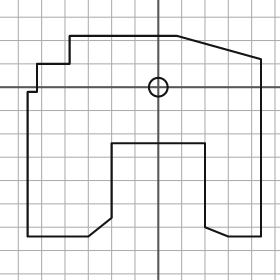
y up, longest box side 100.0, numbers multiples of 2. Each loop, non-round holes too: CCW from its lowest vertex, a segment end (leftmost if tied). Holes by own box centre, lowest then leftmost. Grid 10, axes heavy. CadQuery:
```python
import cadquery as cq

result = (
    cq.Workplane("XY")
    .moveTo(-56.0, -64.0)
    .lineTo(-30.0, -64.0)
    .lineTo(-20.0, -56.0)
    .lineTo(-20.0, -24.0)
    .lineTo(20.0, -24.0)
    .lineTo(20.0, -60.0)
    .lineTo(30.0, -64.0)
    .lineTo(44.0, -64.0)
    .lineTo(44.0, 12.0)
    .lineTo(8.0, 22.0)
    .lineTo(-38.0, 22.0)
    .lineTo(-38.0, 10.0)
    .lineTo(-52.0, 10.0)
    .lineTo(-52.0, -2.0)
    .lineTo(-56.0, -2.0)
    .close()
    .moveTo(0.0, 0.0)
    .circle(4.0)
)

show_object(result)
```